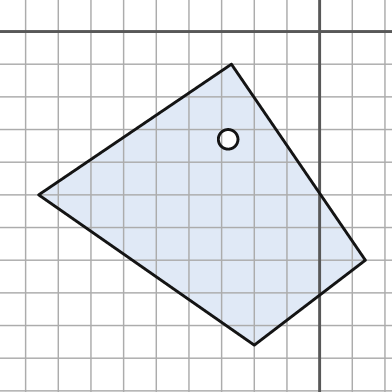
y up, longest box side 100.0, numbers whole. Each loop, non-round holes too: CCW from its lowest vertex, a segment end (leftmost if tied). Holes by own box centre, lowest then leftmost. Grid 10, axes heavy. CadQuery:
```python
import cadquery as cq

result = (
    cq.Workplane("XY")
    .moveTo(-20.0, -96.0)
    .lineTo(14.0, -70.0)
    .lineTo(-27.0, -10.0)
    .lineTo(-86.0, -50.0)
    .close()
    .moveTo(-28.0, -33.0)
    .circle(3.0)
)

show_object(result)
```